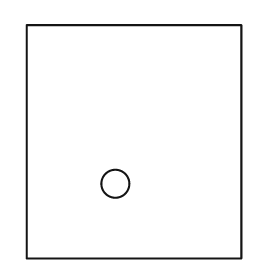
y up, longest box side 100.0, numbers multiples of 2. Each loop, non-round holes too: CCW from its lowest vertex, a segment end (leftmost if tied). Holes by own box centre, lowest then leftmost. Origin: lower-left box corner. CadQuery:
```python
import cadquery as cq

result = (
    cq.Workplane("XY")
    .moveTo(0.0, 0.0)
    .lineTo(92.0, 0.0)
    .lineTo(92.0, 100.0)
    .lineTo(0.0, 100.0)
    .close()
    .moveTo(38.0, 32.0)
    .circle(6.0)
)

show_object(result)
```